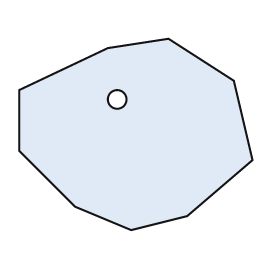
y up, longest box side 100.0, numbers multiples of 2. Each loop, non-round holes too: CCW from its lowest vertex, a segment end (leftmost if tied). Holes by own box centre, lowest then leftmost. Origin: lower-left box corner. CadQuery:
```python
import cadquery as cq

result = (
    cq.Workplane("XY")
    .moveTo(48.0, 0.0)
    .lineTo(72.0, 6.0)
    .lineTo(100.0, 30.0)
    .lineTo(92.0, 64.0)
    .lineTo(64.0, 82.0)
    .lineTo(38.0, 78.0)
    .lineTo(0.0, 60.0)
    .lineTo(0.0, 34.0)
    .lineTo(24.0, 10.0)
    .close()
    .moveTo(42.0, 56.0)
    .circle(4.0)
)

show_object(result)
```